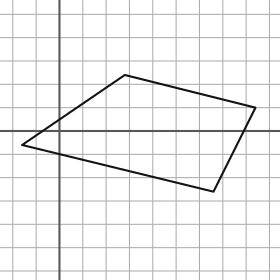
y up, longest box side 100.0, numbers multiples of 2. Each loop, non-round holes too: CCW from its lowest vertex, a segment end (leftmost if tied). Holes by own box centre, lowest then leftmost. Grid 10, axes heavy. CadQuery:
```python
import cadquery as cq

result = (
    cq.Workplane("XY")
    .moveTo(66.0, -26.0)
    .lineTo(84.0, 10.0)
    .lineTo(28.0, 24.0)
    .lineTo(-16.0, -6.0)
    .close()
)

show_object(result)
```